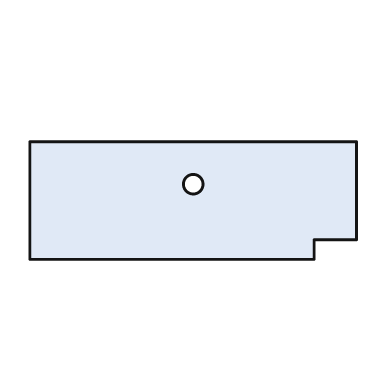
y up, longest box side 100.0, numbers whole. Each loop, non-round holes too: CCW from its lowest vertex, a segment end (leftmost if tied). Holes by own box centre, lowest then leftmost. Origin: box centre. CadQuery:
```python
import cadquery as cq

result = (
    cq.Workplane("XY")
    .moveTo(-50.0, -18.0)
    .lineTo(37.0, -18.0)
    .lineTo(37.0, -12.0)
    .lineTo(50.0, -12.0)
    .lineTo(50.0, 18.0)
    .lineTo(-50.0, 18.0)
    .close()
    .moveTo(0.0, 5.0)
    .circle(3.0)
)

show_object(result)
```